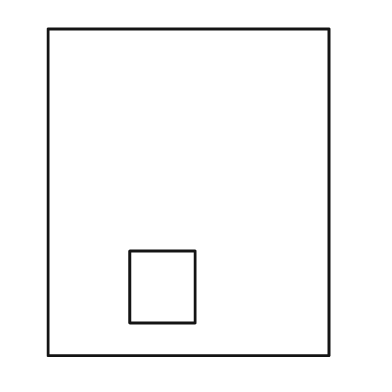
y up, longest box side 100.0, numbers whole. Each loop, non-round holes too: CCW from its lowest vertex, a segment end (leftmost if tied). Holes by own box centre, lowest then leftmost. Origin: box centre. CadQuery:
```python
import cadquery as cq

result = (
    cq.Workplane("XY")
    .moveTo(-43.0, -50.0)
    .lineTo(43.0, -50.0)
    .lineTo(43.0, 50.0)
    .lineTo(-43.0, 50.0)
    .close()
    .moveTo(-18.0, -40.0)
    .lineTo(2.0, -40.0)
    .lineTo(2.0, -18.0)
    .lineTo(-18.0, -18.0)
    .close()
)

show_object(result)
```